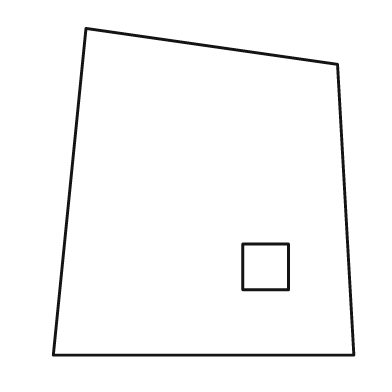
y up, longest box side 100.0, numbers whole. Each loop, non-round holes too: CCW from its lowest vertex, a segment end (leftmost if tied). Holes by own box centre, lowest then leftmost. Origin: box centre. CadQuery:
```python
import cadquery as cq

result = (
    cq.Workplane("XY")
    .moveTo(-46.0, -50.0)
    .lineTo(46.0, -50.0)
    .lineTo(41.0, 39.0)
    .lineTo(-36.0, 50.0)
    .close()
    .moveTo(12.0, -30.0)
    .lineTo(26.0, -30.0)
    .lineTo(26.0, -16.0)
    .lineTo(12.0, -16.0)
    .close()
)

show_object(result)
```